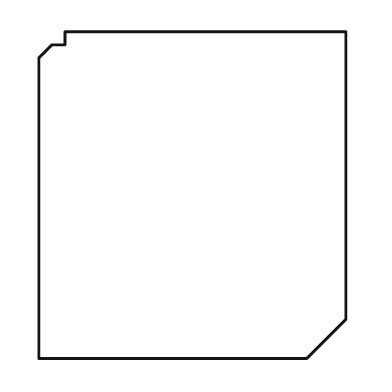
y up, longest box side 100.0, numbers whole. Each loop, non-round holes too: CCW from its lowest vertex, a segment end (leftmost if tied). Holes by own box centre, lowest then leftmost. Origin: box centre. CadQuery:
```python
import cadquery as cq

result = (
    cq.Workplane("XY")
    .moveTo(-47.0, -50.0)
    .lineTo(35.0, -50.0)
    .lineTo(47.0, -38.0)
    .lineTo(47.0, 50.0)
    .lineTo(-39.0, 50.0)
    .lineTo(-39.0, 46.0)
    .lineTo(-43.0, 46.0)
    .lineTo(-47.0, 42.0)
    .close()
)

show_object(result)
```